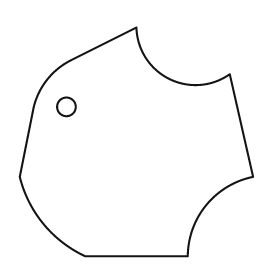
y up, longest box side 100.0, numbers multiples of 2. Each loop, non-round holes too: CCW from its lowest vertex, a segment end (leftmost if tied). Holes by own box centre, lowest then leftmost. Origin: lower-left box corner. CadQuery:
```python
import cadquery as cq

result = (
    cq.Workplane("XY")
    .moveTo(28.0, 0.0)
    .lineTo(72.0, 0.0)
    .threePointArc((80.0, 22.0), (100.0, 34.0))
    .lineTo(90.0, 78.0)
    .threePointArc((64.0, 76.0), (50.0, 98.0))
    .lineTo(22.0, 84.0)
    .threePointArc((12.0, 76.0), (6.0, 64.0))
    .lineTo(0.0, 34.0)
    .threePointArc((10.0, 14.0), (28.0, 0.0))
    .close()
    .moveTo(20.0, 64.0)
    .circle(4.0)
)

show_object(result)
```